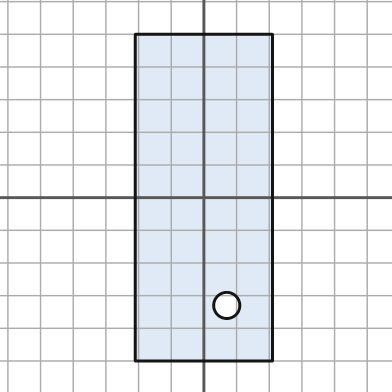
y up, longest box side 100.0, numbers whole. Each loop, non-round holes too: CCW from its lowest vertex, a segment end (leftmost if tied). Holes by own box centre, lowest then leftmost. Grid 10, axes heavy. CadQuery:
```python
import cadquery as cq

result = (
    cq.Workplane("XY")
    .moveTo(-21.0, -50.0)
    .lineTo(21.0, -50.0)
    .lineTo(21.0, 50.0)
    .lineTo(-21.0, 50.0)
    .close()
    .moveTo(7.0, -33.0)
    .circle(4.0)
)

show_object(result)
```